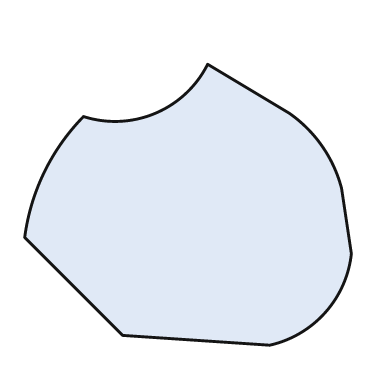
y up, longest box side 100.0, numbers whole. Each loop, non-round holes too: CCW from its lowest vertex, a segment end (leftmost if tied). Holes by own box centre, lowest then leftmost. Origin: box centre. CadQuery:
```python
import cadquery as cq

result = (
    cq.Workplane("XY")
    .moveTo(25.0, -43.0)
    .threePointArc((42.0, -33.0), (50.0, -15.0))
    .lineTo(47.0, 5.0)
    .threePointArc((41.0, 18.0), (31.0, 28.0))
    .lineTo(6.0, 43.0)
    .threePointArc((-10.0, 28.0), (-32.0, 27.0))
    .threePointArc((-44.0, 10.0), (-50.0, -10.0))
    .lineTo(-20.0, -40.0)
    .close()
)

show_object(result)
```